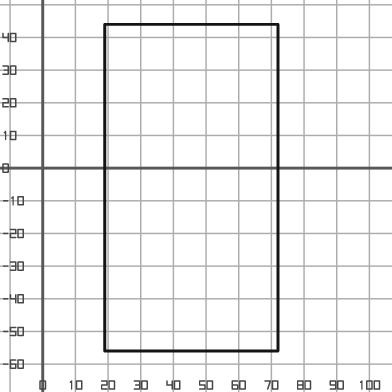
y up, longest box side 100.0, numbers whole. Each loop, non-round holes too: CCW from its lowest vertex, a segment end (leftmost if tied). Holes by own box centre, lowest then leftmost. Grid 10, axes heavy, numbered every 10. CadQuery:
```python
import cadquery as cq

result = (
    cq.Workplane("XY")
    .moveTo(19.0, -56.0)
    .lineTo(72.0, -56.0)
    .lineTo(72.0, 44.0)
    .lineTo(19.0, 44.0)
    .close()
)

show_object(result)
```